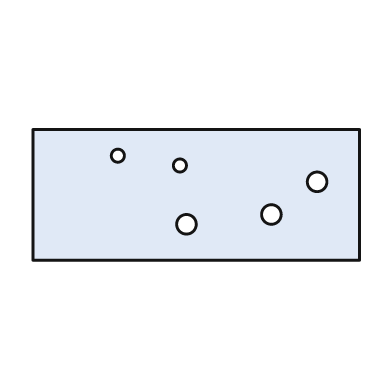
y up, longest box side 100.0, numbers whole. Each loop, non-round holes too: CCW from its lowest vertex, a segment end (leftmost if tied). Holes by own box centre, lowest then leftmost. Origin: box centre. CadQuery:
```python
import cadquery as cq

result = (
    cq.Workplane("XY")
    .moveTo(-50.0, -20.0)
    .lineTo(50.0, -20.0)
    .lineTo(50.0, 20.0)
    .lineTo(-50.0, 20.0)
    .close()
    .moveTo(-3.0, -9.0)
    .circle(3.0)
    .moveTo(23.0, -6.0)
    .circle(3.0)
    .moveTo(37.0, 4.0)
    .circle(3.0)
    .moveTo(-5.0, 9.0)
    .circle(2.0)
    .moveTo(-24.0, 12.0)
    .circle(2.0)
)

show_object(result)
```